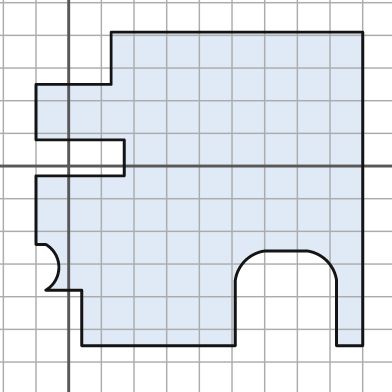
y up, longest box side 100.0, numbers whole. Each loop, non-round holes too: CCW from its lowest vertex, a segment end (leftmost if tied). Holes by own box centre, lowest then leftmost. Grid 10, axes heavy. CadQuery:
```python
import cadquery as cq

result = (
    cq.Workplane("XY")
    .moveTo(4.0, -55.0)
    .lineTo(51.0, -55.0)
    .lineTo(51.0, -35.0)
    .threePointArc((54.0, -29.0), (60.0, -26.0))
    .lineTo(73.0, -26.0)
    .threePointArc((79.0, -29.0), (82.0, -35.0))
    .lineTo(82.0, -55.0)
    .lineTo(90.0, -55.0)
    .lineTo(90.0, 41.0)
    .lineTo(13.0, 41.0)
    .lineTo(13.0, 25.0)
    .lineTo(-10.0, 25.0)
    .lineTo(-10.0, 8.0)
    .lineTo(17.0, 8.0)
    .lineTo(17.0, -3.0)
    .lineTo(-10.0, -3.0)
    .lineTo(-10.0, -24.0)
    .lineTo(-7.0, -24.0)
    .threePointArc((-3.0, -31.0), (-7.0, -38.0))
    .lineTo(4.0, -38.0)
    .close()
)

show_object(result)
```